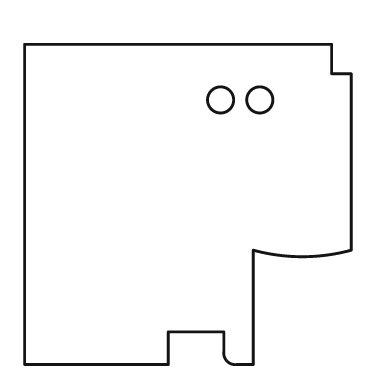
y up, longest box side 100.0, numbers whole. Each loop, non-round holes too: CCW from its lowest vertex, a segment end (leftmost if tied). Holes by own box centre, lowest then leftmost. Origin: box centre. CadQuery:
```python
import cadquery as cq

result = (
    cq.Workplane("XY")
    .moveTo(-50.0, -49.0)
    .lineTo(-6.0, -49.0)
    .lineTo(-6.0, -39.0)
    .lineTo(11.0, -39.0)
    .lineTo(11.0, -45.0)
    .threePointArc((12.0, -48.0), (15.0, -49.0))
    .lineTo(20.0, -49.0)
    .lineTo(20.0, -14.0)
    .threePointArc((35.0, -16.0), (50.0, -14.0))
    .lineTo(50.0, 40.0)
    .lineTo(44.0, 40.0)
    .lineTo(44.0, 49.0)
    .lineTo(-50.0, 49.0)
    .close()
    .moveTo(10.0, 32.0)
    .circle(4.0)
    .moveTo(22.0, 32.0)
    .circle(4.0)
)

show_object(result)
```